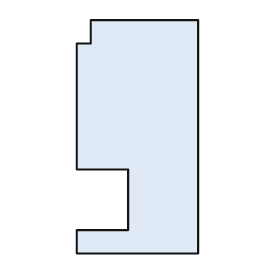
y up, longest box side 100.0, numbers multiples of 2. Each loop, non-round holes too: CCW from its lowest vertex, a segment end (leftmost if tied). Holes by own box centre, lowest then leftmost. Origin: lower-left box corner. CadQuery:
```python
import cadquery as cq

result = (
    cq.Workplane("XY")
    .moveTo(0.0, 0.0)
    .lineTo(52.0, 0.0)
    .lineTo(52.0, 100.0)
    .lineTo(6.0, 100.0)
    .lineTo(6.0, 90.0)
    .lineTo(0.0, 90.0)
    .lineTo(0.0, 36.0)
    .lineTo(22.0, 36.0)
    .lineTo(22.0, 10.0)
    .lineTo(0.0, 10.0)
    .close()
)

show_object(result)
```